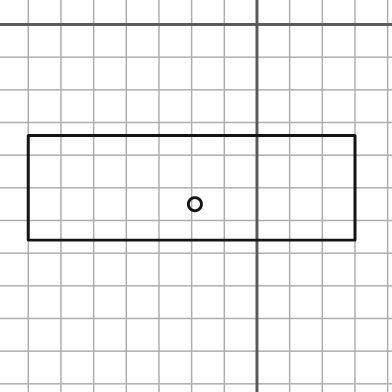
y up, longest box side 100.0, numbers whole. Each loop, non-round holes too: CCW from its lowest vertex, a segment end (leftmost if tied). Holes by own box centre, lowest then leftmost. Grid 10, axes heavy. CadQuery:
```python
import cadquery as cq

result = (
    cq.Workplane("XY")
    .moveTo(-70.0, -66.0)
    .lineTo(30.0, -66.0)
    .lineTo(30.0, -34.0)
    .lineTo(-70.0, -34.0)
    .close()
    .moveTo(-19.0, -55.0)
    .circle(2.0)
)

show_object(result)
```